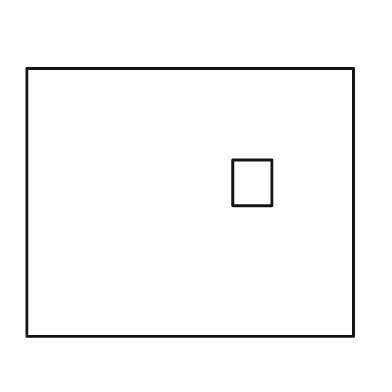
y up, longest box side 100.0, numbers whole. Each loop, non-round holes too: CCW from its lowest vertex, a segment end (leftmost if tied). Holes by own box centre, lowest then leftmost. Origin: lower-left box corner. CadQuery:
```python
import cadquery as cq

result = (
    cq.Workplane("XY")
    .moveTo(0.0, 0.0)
    .lineTo(100.0, 0.0)
    .lineTo(100.0, 82.0)
    .lineTo(0.0, 82.0)
    .close()
    .moveTo(63.0, 40.0)
    .lineTo(75.0, 40.0)
    .lineTo(75.0, 54.0)
    .lineTo(63.0, 54.0)
    .close()
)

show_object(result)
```